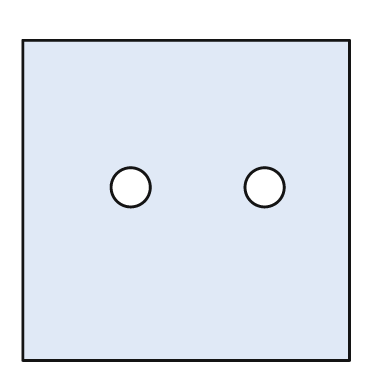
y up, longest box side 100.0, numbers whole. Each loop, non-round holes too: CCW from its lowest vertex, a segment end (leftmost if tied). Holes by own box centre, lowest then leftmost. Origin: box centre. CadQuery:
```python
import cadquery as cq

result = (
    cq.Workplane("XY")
    .moveTo(-50.0, -49.0)
    .lineTo(50.0, -49.0)
    .lineTo(50.0, 49.0)
    .lineTo(-50.0, 49.0)
    .close()
    .moveTo(-17.0, 4.0)
    .circle(6.0)
    .moveTo(24.0, 4.0)
    .circle(6.0)
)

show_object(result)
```